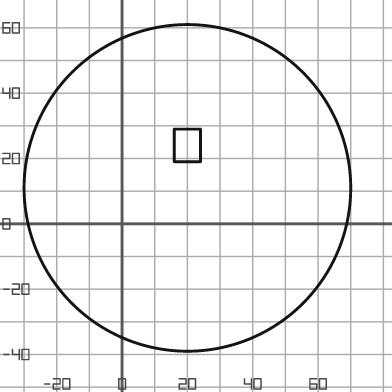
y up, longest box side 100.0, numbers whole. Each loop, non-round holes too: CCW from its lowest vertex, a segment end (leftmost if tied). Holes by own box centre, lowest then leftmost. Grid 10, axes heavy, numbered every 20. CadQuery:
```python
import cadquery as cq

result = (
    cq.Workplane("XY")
    .moveTo(20.0, 11.0)
    .circle(50.0)
    .moveTo(16.0, 19.0)
    .lineTo(24.0, 19.0)
    .lineTo(24.0, 29.0)
    .lineTo(16.0, 29.0)
    .close()
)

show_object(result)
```